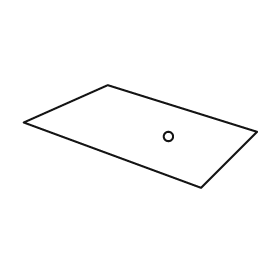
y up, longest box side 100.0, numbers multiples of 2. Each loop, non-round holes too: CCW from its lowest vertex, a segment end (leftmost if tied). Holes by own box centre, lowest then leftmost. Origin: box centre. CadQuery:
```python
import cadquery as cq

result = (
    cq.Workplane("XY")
    .moveTo(26.0, -22.0)
    .lineTo(50.0, 2.0)
    .lineTo(-14.0, 22.0)
    .lineTo(-50.0, 6.0)
    .close()
    .moveTo(12.0, 0.0)
    .circle(2.0)
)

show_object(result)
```